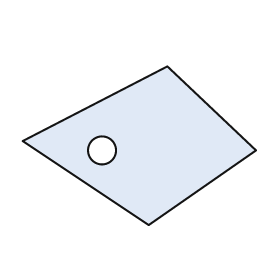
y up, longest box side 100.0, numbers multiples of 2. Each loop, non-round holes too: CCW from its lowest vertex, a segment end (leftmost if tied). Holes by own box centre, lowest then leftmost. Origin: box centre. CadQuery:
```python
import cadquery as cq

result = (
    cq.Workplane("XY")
    .moveTo(4.0, -34.0)
    .lineTo(50.0, -2.0)
    .lineTo(12.0, 34.0)
    .lineTo(-50.0, 2.0)
    .close()
    .moveTo(-16.0, -2.0)
    .circle(6.0)
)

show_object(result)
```